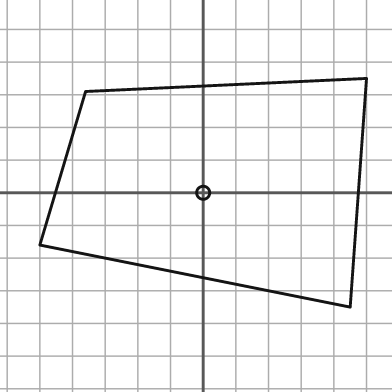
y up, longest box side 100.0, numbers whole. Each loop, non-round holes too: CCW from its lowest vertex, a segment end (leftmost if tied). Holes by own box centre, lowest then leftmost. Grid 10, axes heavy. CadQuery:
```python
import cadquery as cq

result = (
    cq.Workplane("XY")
    .moveTo(45.0, -35.0)
    .lineTo(50.0, 35.0)
    .lineTo(-36.0, 31.0)
    .lineTo(-50.0, -16.0)
    .close()
    .moveTo(0.0, 0.0)
    .circle(2.0)
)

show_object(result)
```